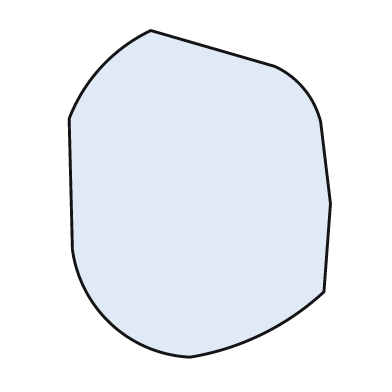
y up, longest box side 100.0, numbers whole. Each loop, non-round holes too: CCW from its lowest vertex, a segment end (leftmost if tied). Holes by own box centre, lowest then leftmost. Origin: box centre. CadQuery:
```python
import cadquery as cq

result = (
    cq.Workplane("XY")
    .moveTo(-3.0, -50.0)
    .threePointArc((19.0, -43.0), (38.0, -30.0))
    .lineTo(40.0, -3.0)
    .lineTo(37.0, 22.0)
    .threePointArc((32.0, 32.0), (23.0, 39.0))
    .lineTo(-15.0, 50.0)
    .threePointArc((-30.0, 39.0), (-40.0, 23.0))
    .lineTo(-39.0, -17.0)
    .threePointArc((-27.0, -40.0), (-3.0, -50.0))
    .close()
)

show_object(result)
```